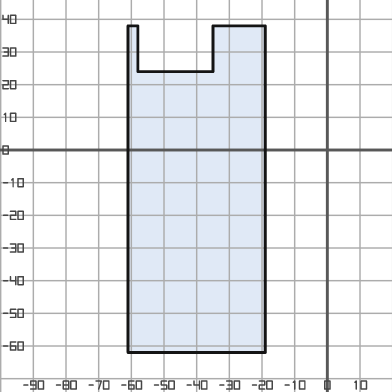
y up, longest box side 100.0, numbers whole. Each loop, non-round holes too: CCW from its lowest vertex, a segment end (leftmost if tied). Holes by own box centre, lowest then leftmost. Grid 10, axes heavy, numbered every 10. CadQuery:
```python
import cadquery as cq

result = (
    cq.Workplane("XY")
    .moveTo(-61.0, -62.0)
    .lineTo(-19.0, -62.0)
    .lineTo(-19.0, 38.0)
    .lineTo(-35.0, 38.0)
    .lineTo(-35.0, 24.0)
    .lineTo(-58.0, 24.0)
    .lineTo(-58.0, 38.0)
    .lineTo(-61.0, 38.0)
    .close()
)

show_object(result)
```